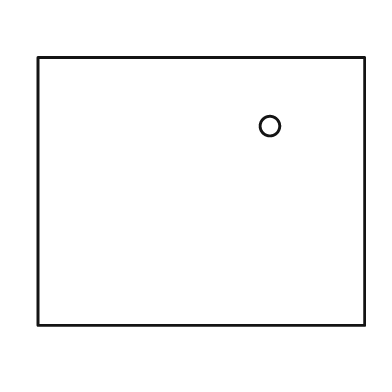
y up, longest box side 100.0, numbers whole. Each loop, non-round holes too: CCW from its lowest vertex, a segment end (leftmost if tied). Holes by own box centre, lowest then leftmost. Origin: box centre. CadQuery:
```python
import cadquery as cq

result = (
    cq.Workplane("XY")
    .moveTo(-50.0, -41.0)
    .lineTo(50.0, -41.0)
    .lineTo(50.0, 41.0)
    .lineTo(-50.0, 41.0)
    .close()
    .moveTo(21.0, 20.0)
    .circle(3.0)
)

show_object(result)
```